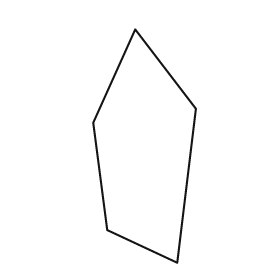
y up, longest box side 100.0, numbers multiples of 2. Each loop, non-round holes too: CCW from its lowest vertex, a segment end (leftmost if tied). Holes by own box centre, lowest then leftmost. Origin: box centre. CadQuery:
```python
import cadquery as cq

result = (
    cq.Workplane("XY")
    .moveTo(14.0, -50.0)
    .lineTo(22.0, 16.0)
    .lineTo(-4.0, 50.0)
    .lineTo(-22.0, 10.0)
    .lineTo(-16.0, -36.0)
    .close()
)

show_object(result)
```